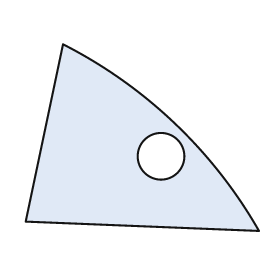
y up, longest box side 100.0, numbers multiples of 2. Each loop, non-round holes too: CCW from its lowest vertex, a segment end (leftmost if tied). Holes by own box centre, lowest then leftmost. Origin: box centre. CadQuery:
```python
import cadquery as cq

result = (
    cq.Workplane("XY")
    .moveTo(50.0, -40.0)
    .threePointArc((14.0, 6.0), (-34.0, 40.0))
    .lineTo(-50.0, -36.0)
    .close()
    .moveTo(8.0, -8.0)
    .circle(10.0)
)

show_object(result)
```